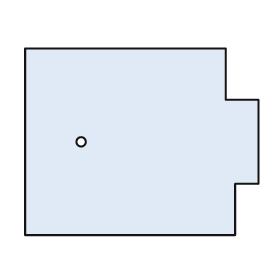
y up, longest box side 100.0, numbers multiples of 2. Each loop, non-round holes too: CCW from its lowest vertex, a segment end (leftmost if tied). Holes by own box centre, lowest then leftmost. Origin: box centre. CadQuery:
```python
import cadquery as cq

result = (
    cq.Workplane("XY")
    .moveTo(-50.0, -40.0)
    .lineTo(40.0, -40.0)
    .lineTo(40.0, -18.0)
    .lineTo(50.0, -18.0)
    .lineTo(50.0, 18.0)
    .lineTo(36.0, 18.0)
    .lineTo(36.0, 40.0)
    .lineTo(-50.0, 40.0)
    .close()
    .moveTo(-26.0, 0.0)
    .circle(2.0)
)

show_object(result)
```